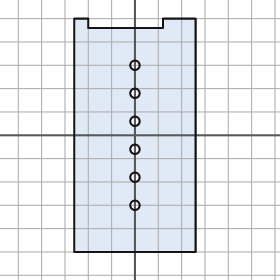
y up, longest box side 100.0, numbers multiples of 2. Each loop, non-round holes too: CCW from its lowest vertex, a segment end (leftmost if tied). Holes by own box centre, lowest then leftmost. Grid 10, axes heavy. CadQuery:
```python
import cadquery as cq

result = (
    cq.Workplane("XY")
    .moveTo(-26.0, -50.0)
    .lineTo(26.0, -50.0)
    .lineTo(26.0, 50.0)
    .lineTo(12.0, 50.0)
    .lineTo(12.0, 46.0)
    .lineTo(-20.0, 46.0)
    .lineTo(-20.0, 50.0)
    .lineTo(-26.0, 50.0)
    .close()
    .moveTo(0.0, -30.0)
    .circle(2.0)
    .moveTo(0.0, -18.0)
    .circle(2.0)
    .moveTo(0.0, -6.0)
    .circle(2.0)
    .moveTo(0.0, 6.0)
    .circle(2.0)
    .moveTo(0.0, 18.0)
    .circle(2.0)
    .moveTo(0.0, 30.0)
    .circle(2.0)
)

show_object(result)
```